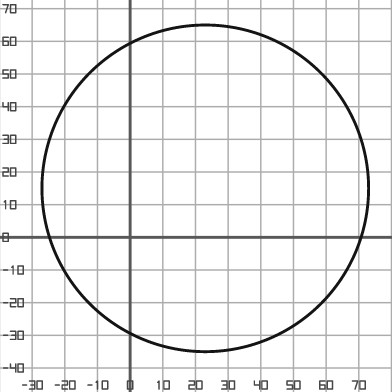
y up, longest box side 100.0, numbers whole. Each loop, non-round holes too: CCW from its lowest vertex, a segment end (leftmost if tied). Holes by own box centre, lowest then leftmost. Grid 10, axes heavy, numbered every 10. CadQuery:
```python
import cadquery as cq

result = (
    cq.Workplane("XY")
    .moveTo(23.0, 15.0)
    .circle(50.0)
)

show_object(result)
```